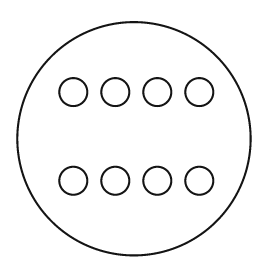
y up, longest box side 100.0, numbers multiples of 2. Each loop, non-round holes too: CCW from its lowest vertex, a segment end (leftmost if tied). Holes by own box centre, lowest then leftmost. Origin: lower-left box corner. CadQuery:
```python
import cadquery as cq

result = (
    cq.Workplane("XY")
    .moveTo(50.0, 50.0)
    .circle(50.0)
    .moveTo(24.0, 32.0)
    .circle(6.0)
    .moveTo(42.0, 32.0)
    .circle(6.0)
    .moveTo(60.0, 32.0)
    .circle(6.0)
    .moveTo(78.0, 32.0)
    .circle(6.0)
    .moveTo(24.0, 70.0)
    .circle(6.0)
    .moveTo(42.0, 70.0)
    .circle(6.0)
    .moveTo(60.0, 70.0)
    .circle(6.0)
    .moveTo(78.0, 70.0)
    .circle(6.0)
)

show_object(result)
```